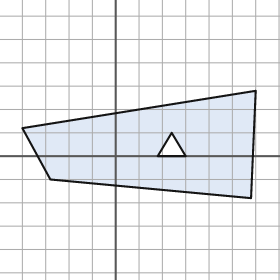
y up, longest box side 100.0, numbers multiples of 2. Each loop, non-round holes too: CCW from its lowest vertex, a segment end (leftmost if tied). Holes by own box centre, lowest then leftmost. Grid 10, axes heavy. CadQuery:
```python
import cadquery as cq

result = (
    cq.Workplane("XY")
    .moveTo(58.0, -18.0)
    .lineTo(60.0, 28.0)
    .lineTo(-40.0, 12.0)
    .lineTo(-28.0, -10.0)
    .close()
    .moveTo(18.0, 0.0)
    .lineTo(30.0, 0.0)
    .lineTo(24.0, 10.0)
    .close()
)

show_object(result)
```